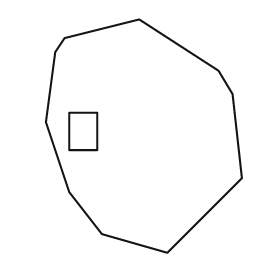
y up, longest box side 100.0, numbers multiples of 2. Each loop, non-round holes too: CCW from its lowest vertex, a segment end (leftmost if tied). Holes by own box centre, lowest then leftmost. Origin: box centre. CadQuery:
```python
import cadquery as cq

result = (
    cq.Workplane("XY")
    .moveTo(10.0, -50.0)
    .lineTo(42.0, -18.0)
    .lineTo(38.0, 18.0)
    .lineTo(32.0, 28.0)
    .lineTo(-2.0, 50.0)
    .lineTo(-34.0, 42.0)
    .lineTo(-38.0, 36.0)
    .lineTo(-42.0, 6.0)
    .lineTo(-32.0, -24.0)
    .lineTo(-18.0, -42.0)
    .close()
    .moveTo(-32.0, -6.0)
    .lineTo(-20.0, -6.0)
    .lineTo(-20.0, 10.0)
    .lineTo(-32.0, 10.0)
    .close()
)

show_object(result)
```